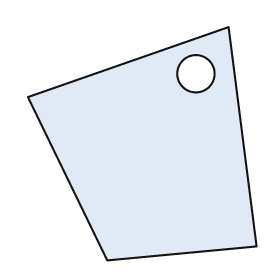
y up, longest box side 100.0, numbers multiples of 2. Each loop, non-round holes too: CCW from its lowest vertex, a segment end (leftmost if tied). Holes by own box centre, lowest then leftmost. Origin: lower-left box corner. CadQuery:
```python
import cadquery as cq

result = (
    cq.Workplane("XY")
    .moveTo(34.0, 0.0)
    .lineTo(98.0, 6.0)
    .lineTo(86.0, 100.0)
    .lineTo(0.0, 70.0)
    .close()
    .moveTo(72.0, 80.0)
    .circle(8.0)
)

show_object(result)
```